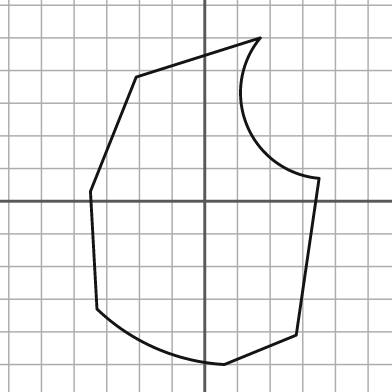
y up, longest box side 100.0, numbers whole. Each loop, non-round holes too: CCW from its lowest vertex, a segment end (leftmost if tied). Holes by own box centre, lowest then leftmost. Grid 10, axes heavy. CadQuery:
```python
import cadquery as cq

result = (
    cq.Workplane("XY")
    .moveTo(6.0, -50.0)
    .lineTo(28.0, -41.0)
    .lineTo(35.0, 7.0)
    .threePointArc((13.0, 23.0), (17.0, 50.0))
    .lineTo(-21.0, 38.0)
    .lineTo(-35.0, 3.0)
    .lineTo(-33.0, -33.0)
    .threePointArc((-15.0, -45.0), (6.0, -50.0))
    .close()
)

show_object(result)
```